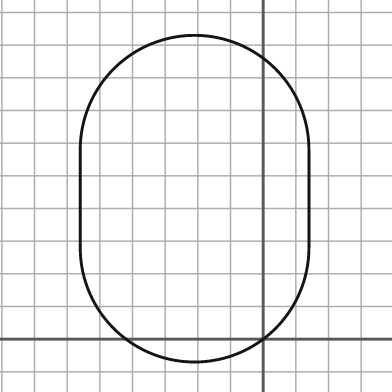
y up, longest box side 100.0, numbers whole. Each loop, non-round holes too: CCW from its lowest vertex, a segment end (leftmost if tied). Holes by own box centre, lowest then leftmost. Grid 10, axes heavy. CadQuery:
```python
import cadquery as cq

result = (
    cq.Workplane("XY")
    .moveTo(-56.0, 28.0)
    .threePointArc((-21.0, -7.0), (14.0, 28.0))
    .lineTo(14.0, 58.0)
    .threePointArc((-21.0, 93.0), (-56.0, 58.0))
    .close()
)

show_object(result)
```